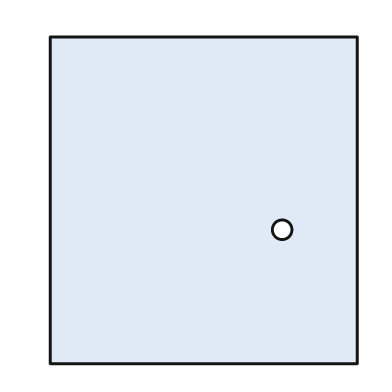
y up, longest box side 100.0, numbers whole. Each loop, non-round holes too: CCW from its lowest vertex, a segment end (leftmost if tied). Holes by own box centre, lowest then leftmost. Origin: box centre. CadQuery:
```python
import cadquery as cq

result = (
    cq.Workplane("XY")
    .moveTo(-47.0, -50.0)
    .lineTo(47.0, -50.0)
    .lineTo(47.0, 50.0)
    .lineTo(-47.0, 50.0)
    .close()
    .moveTo(24.0, -9.0)
    .circle(3.0)
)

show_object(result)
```